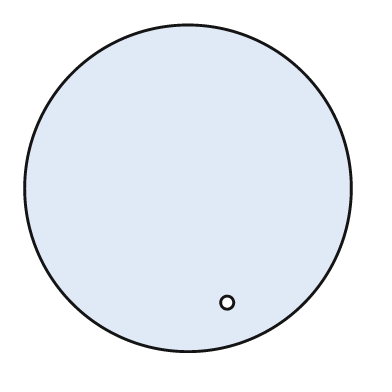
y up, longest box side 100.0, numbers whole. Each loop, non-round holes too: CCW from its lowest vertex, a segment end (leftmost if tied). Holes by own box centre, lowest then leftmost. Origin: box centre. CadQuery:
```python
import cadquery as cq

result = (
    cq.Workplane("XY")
    .moveTo(0.0, 0.0)
    .circle(50.0)
    .moveTo(12.0, -35.0)
    .circle(2.0)
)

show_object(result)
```